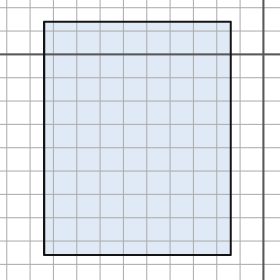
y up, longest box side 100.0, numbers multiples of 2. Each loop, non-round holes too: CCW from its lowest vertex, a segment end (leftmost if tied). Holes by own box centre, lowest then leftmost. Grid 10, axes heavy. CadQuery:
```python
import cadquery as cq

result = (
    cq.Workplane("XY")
    .moveTo(-94.0, -86.0)
    .lineTo(-14.0, -86.0)
    .lineTo(-14.0, 14.0)
    .lineTo(-94.0, 14.0)
    .close()
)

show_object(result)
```